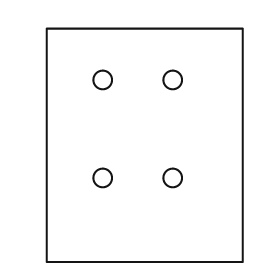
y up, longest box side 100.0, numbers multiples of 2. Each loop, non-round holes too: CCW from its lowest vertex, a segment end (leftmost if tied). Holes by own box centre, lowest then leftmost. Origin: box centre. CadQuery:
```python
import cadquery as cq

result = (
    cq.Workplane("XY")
    .moveTo(-42.0, -50.0)
    .lineTo(42.0, -50.0)
    .lineTo(42.0, 50.0)
    .lineTo(-42.0, 50.0)
    .close()
    .moveTo(-18.0, -14.0)
    .circle(4.0)
    .moveTo(12.0, -14.0)
    .circle(4.0)
    .moveTo(-18.0, 28.0)
    .circle(4.0)
    .moveTo(12.0, 28.0)
    .circle(4.0)
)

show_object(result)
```